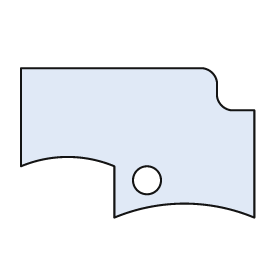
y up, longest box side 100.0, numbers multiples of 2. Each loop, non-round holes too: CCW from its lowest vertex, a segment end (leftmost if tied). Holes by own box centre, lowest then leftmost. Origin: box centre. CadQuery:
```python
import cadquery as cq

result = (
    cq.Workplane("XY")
    .moveTo(-10.0, -32.0)
    .threePointArc((20.0, -26.0), (50.0, -32.0))
    .lineTo(50.0, 14.0)
    .lineTo(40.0, 14.0)
    .threePointArc((36.0, 16.0), (34.0, 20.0))
    .lineTo(34.0, 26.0)
    .threePointArc((32.0, 30.0), (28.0, 32.0))
    .lineTo(-50.0, 32.0)
    .lineTo(-50.0, -10.0)
    .threePointArc((-30.0, -6.0), (-10.0, -10.0))
    .close()
    .moveTo(4.0, -16.0)
    .circle(6.0)
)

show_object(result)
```